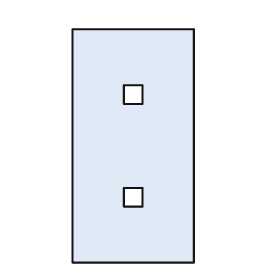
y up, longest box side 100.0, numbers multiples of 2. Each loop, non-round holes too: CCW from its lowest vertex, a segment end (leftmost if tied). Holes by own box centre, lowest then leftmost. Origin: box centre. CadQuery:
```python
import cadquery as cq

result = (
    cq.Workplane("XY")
    .moveTo(-26.0, -50.0)
    .lineTo(26.0, -50.0)
    .lineTo(26.0, 50.0)
    .lineTo(-26.0, 50.0)
    .close()
    .moveTo(-4.0, -26.0)
    .lineTo(4.0, -26.0)
    .lineTo(4.0, -18.0)
    .lineTo(-4.0, -18.0)
    .close()
    .moveTo(-4.0, 18.0)
    .lineTo(4.0, 18.0)
    .lineTo(4.0, 26.0)
    .lineTo(-4.0, 26.0)
    .close()
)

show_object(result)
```